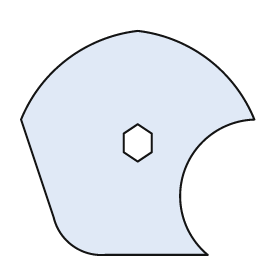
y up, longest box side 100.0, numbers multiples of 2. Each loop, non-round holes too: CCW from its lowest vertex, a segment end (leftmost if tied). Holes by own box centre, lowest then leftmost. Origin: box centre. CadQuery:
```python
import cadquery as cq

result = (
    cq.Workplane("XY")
    .moveTo(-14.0, -48.0)
    .lineTo(30.0, -48.0)
    .threePointArc((20.0, -12.0), (50.0, 10.0))
    .threePointArc((30.0, 36.0), (0.0, 48.0))
    .threePointArc((-30.0, 36.0), (-50.0, 10.0))
    .lineTo(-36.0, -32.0)
    .threePointArc((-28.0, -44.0), (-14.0, -48.0))
    .close()
    .moveTo(0.0, -8.0)
    .lineTo(6.0, -4.0)
    .lineTo(6.0, 4.0)
    .lineTo(0.0, 8.0)
    .lineTo(-6.0, 4.0)
    .lineTo(-6.0, -4.0)
    .close()
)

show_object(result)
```